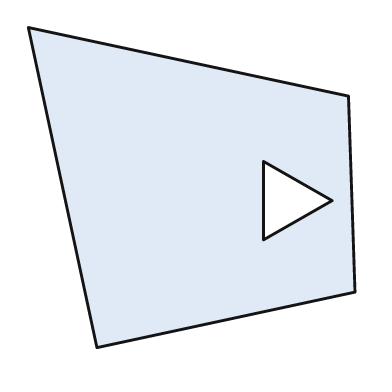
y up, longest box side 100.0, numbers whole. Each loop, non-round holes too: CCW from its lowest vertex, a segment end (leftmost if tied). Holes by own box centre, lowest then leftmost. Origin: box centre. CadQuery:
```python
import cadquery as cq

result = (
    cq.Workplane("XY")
    .moveTo(-29.0, -49.0)
    .lineTo(50.0, -32.0)
    .lineTo(48.0, 28.0)
    .lineTo(-50.0, 49.0)
    .close()
    .moveTo(22.0, -16.0)
    .lineTo(43.0, -4.0)
    .lineTo(22.0, 8.0)
    .close()
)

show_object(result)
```